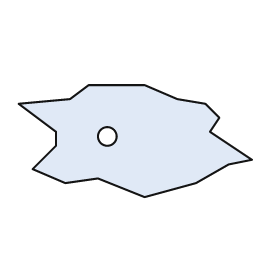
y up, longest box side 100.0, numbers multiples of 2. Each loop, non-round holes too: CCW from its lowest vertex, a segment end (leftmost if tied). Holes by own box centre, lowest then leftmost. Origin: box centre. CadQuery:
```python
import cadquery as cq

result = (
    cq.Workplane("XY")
    .moveTo(4.0, -24.0)
    .lineTo(26.0, -18.0)
    .lineTo(40.0, -10.0)
    .lineTo(50.0, -8.0)
    .lineTo(32.0, 4.0)
    .lineTo(36.0, 10.0)
    .lineTo(30.0, 16.0)
    .lineTo(18.0, 18.0)
    .lineTo(4.0, 24.0)
    .lineTo(-20.0, 24.0)
    .lineTo(-28.0, 18.0)
    .lineTo(-50.0, 16.0)
    .lineTo(-34.0, 4.0)
    .lineTo(-34.0, -2.0)
    .lineTo(-44.0, -12.0)
    .lineTo(-30.0, -18.0)
    .lineTo(-16.0, -16.0)
    .close()
    .moveTo(-12.0, 2.0)
    .circle(4.0)
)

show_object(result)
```